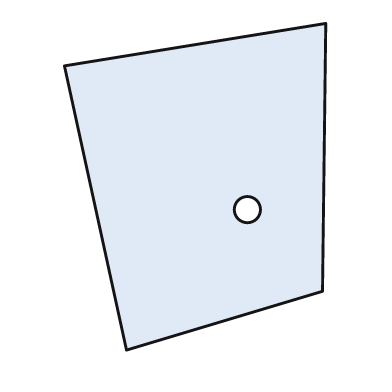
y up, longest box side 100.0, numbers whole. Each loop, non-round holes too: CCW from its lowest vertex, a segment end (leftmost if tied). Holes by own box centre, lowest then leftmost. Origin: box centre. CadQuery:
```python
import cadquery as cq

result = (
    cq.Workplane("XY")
    .moveTo(-21.0, -50.0)
    .lineTo(39.0, -32.0)
    .lineTo(40.0, 50.0)
    .lineTo(-40.0, 37.0)
    .close()
    .moveTo(16.0, -7.0)
    .circle(4.0)
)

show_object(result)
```